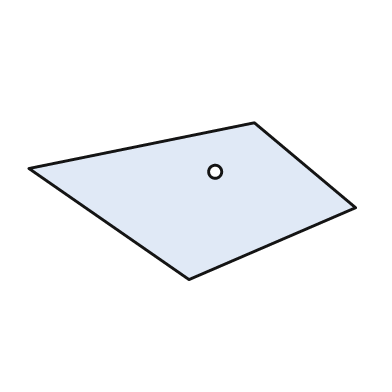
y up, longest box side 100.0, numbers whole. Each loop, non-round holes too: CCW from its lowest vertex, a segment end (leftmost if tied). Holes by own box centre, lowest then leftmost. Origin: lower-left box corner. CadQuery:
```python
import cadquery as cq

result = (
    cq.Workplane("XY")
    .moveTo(49.0, 0.0)
    .lineTo(100.0, 22.0)
    .lineTo(69.0, 48.0)
    .lineTo(0.0, 34.0)
    .close()
    .moveTo(57.0, 33.0)
    .circle(2.0)
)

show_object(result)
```